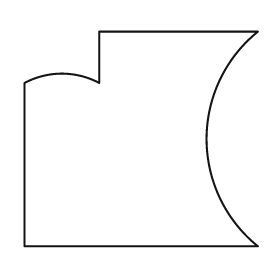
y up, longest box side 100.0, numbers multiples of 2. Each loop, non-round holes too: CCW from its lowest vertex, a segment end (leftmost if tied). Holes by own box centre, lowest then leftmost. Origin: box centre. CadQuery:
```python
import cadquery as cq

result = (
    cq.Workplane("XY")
    .moveTo(-50.0, -46.0)
    .lineTo(50.0, -46.0)
    .threePointArc((28.0, 0.0), (50.0, 46.0))
    .lineTo(-18.0, 46.0)
    .lineTo(-18.0, 24.0)
    .threePointArc((-34.0, 28.0), (-50.0, 24.0))
    .close()
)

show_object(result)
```